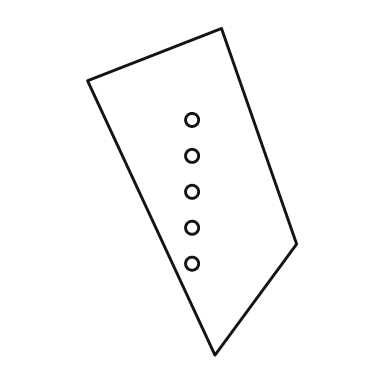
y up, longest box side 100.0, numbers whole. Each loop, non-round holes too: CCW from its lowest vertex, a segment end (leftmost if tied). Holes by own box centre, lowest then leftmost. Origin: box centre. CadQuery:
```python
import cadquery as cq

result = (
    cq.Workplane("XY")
    .moveTo(7.0, -50.0)
    .lineTo(32.0, -16.0)
    .lineTo(9.0, 50.0)
    .lineTo(-32.0, 34.0)
    .close()
    .moveTo(0.0, -22.0)
    .circle(2.0)
    .moveTo(0.0, -11.0)
    .circle(2.0)
    .moveTo(0.0, 0.0)
    .circle(2.0)
    .moveTo(0.0, 11.0)
    .circle(2.0)
    .moveTo(0.0, 22.0)
    .circle(2.0)
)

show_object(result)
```